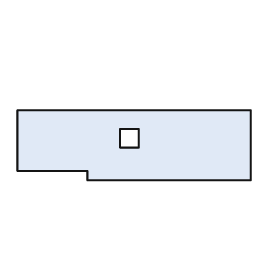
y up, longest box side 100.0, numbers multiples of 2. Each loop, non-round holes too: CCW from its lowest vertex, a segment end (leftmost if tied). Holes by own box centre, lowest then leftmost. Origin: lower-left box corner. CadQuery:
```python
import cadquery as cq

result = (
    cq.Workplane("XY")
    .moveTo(30.0, 0.0)
    .lineTo(100.0, 0.0)
    .lineTo(100.0, 30.0)
    .lineTo(0.0, 30.0)
    .lineTo(0.0, 4.0)
    .lineTo(30.0, 4.0)
    .close()
    .moveTo(44.0, 14.0)
    .lineTo(52.0, 14.0)
    .lineTo(52.0, 22.0)
    .lineTo(44.0, 22.0)
    .close()
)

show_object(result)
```